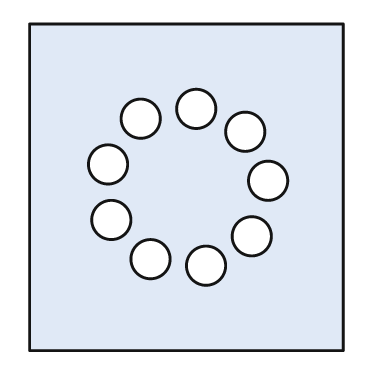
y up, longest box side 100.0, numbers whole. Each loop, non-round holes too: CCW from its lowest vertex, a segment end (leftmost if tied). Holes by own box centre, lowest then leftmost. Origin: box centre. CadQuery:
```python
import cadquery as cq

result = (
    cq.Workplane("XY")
    .moveTo(-48.0, -50.0)
    .lineTo(48.0, -50.0)
    .lineTo(48.0, 50.0)
    .lineTo(-48.0, 50.0)
    .close()
    .moveTo(6.0, -24.0)
    .circle(6.0)
    .moveTo(-11.0, -22.0)
    .circle(6.0)
    .moveTo(20.0, -15.0)
    .circle(6.0)
    .moveTo(-23.0, -10.0)
    .circle(6.0)
    .moveTo(25.0, 2.0)
    .circle(6.0)
    .moveTo(-24.0, 7.0)
    .circle(6.0)
    .moveTo(18.0, 17.0)
    .circle(6.0)
    .moveTo(-14.0, 21.0)
    .circle(6.0)
    .moveTo(3.0, 24.0)
    .circle(6.0)
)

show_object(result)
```